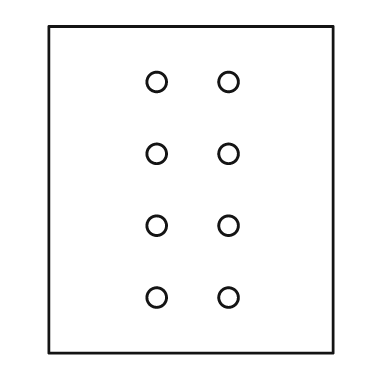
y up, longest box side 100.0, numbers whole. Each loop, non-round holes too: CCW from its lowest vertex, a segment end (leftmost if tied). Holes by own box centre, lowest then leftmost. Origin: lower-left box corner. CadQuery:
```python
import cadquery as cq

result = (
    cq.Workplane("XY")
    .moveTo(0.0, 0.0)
    .lineTo(87.0, 0.0)
    .lineTo(87.0, 100.0)
    .lineTo(0.0, 100.0)
    .close()
    .moveTo(33.0, 17.0)
    .circle(3.0)
    .moveTo(55.0, 17.0)
    .circle(3.0)
    .moveTo(33.0, 39.0)
    .circle(3.0)
    .moveTo(55.0, 39.0)
    .circle(3.0)
    .moveTo(33.0, 61.0)
    .circle(3.0)
    .moveTo(55.0, 61.0)
    .circle(3.0)
    .moveTo(33.0, 83.0)
    .circle(3.0)
    .moveTo(55.0, 83.0)
    .circle(3.0)
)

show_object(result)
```